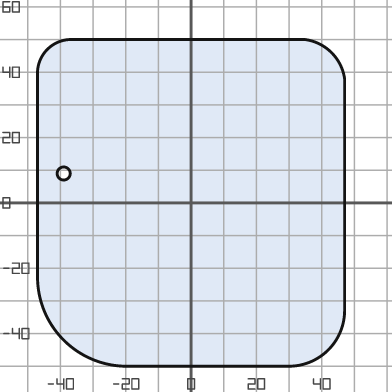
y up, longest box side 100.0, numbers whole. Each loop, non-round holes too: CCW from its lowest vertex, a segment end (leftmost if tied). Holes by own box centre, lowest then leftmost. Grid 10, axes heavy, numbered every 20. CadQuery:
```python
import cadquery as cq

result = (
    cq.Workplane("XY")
    .moveTo(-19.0, -50.0)
    .lineTo(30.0, -50.0)
    .threePointArc((42.0, -45.0), (47.0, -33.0))
    .lineTo(47.0, 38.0)
    .threePointArc((43.0, 46.0), (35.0, 50.0))
    .lineTo(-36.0, 50.0)
    .threePointArc((-44.0, 47.0), (-47.0, 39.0))
    .lineTo(-47.0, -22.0)
    .threePointArc((-39.0, -42.0), (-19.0, -50.0))
    .close()
    .moveTo(-39.0, 9.0)
    .circle(2.0)
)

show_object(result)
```